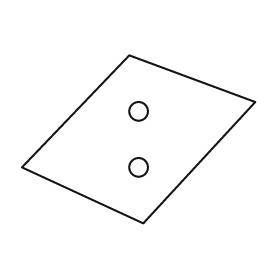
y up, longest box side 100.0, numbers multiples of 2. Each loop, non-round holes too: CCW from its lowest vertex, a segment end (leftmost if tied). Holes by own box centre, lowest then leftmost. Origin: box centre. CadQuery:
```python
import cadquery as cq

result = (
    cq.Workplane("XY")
    .moveTo(2.0, -36.0)
    .lineTo(50.0, 16.0)
    .lineTo(-4.0, 36.0)
    .lineTo(-50.0, -12.0)
    .close()
    .moveTo(0.0, -12.0)
    .circle(4.0)
    .moveTo(0.0, 12.0)
    .circle(4.0)
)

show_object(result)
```